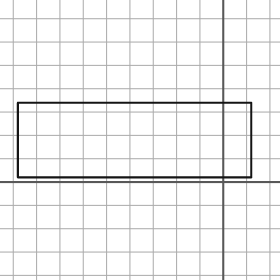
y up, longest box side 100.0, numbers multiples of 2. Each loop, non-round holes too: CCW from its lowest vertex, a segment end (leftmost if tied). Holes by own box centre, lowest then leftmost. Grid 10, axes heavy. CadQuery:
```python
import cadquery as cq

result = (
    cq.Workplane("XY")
    .moveTo(-88.0, 2.0)
    .lineTo(12.0, 2.0)
    .lineTo(12.0, 34.0)
    .lineTo(-88.0, 34.0)
    .close()
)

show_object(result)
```